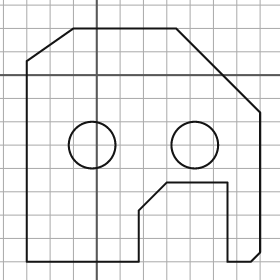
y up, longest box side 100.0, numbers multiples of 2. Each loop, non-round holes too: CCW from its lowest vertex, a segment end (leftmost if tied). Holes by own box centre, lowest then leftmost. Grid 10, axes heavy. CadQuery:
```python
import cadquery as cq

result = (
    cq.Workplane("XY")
    .moveTo(-30.0, -80.0)
    .lineTo(18.0, -80.0)
    .lineTo(18.0, -58.0)
    .lineTo(30.0, -46.0)
    .lineTo(56.0, -46.0)
    .lineTo(56.0, -80.0)
    .lineTo(66.0, -80.0)
    .lineTo(70.0, -76.0)
    .lineTo(70.0, -16.0)
    .lineTo(34.0, 20.0)
    .lineTo(-10.0, 20.0)
    .lineTo(-30.0, 6.0)
    .close()
    .moveTo(-2.0, -30.0)
    .circle(10.0)
    .moveTo(42.0, -30.0)
    .circle(10.0)
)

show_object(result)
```